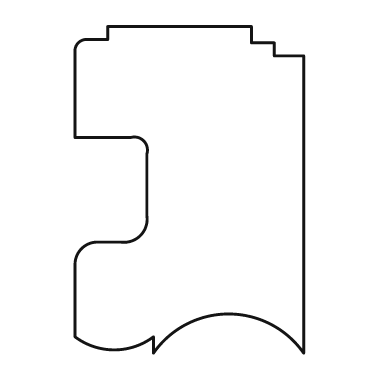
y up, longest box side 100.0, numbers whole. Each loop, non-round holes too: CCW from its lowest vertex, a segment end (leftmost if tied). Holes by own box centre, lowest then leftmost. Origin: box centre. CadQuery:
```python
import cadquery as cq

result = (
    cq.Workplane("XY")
    .moveTo(-11.0, -50.0)
    .threePointArc((12.0, -38.0), (35.0, -50.0))
    .lineTo(35.0, 41.0)
    .lineTo(26.0, 41.0)
    .lineTo(26.0, 45.0)
    .lineTo(19.0, 45.0)
    .lineTo(19.0, 50.0)
    .lineTo(-25.0, 50.0)
    .lineTo(-25.0, 46.0)
    .lineTo(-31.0, 46.0)
    .threePointArc((-34.0, 45.0), (-35.0, 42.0))
    .lineTo(-35.0, 16.0)
    .lineTo(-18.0, 16.0)
    .threePointArc((-14.0, 15.0), (-13.0, 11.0))
    .lineTo(-13.0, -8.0)
    .threePointArc((-15.0, -14.0), (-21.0, -16.0))
    .lineTo(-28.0, -16.0)
    .threePointArc((-33.0, -18.0), (-35.0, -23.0))
    .lineTo(-35.0, -45.0)
    .threePointArc((-23.0, -49.0), (-11.0, -45.0))
    .close()
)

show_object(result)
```